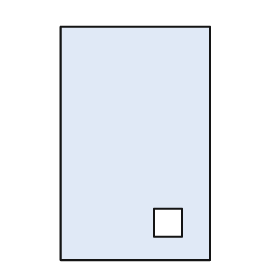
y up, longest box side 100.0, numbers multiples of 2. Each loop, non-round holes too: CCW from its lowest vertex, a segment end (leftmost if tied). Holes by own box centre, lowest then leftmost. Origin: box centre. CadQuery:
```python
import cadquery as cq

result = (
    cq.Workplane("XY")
    .moveTo(-32.0, -50.0)
    .lineTo(32.0, -50.0)
    .lineTo(32.0, 50.0)
    .lineTo(-32.0, 50.0)
    .close()
    .moveTo(8.0, -40.0)
    .lineTo(20.0, -40.0)
    .lineTo(20.0, -28.0)
    .lineTo(8.0, -28.0)
    .close()
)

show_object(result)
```